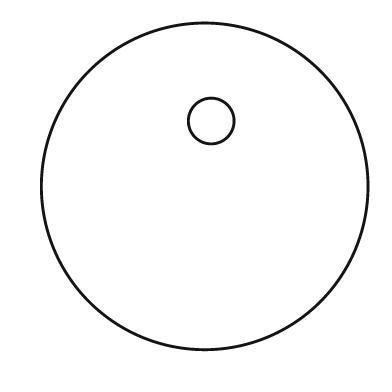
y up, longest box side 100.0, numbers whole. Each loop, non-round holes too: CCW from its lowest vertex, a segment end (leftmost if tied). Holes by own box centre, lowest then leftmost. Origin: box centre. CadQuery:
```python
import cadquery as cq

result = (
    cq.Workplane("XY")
    .moveTo(0.0, 0.0)
    .circle(50.0)
    .moveTo(2.0, 20.0)
    .circle(7.0)
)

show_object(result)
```